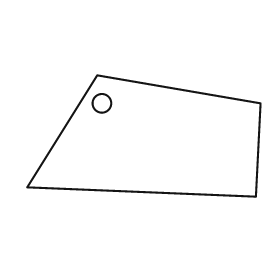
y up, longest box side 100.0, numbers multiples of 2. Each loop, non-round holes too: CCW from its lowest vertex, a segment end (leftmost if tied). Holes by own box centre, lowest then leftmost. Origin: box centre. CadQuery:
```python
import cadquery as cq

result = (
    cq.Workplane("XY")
    .moveTo(48.0, -26.0)
    .lineTo(50.0, 14.0)
    .lineTo(-20.0, 26.0)
    .lineTo(-50.0, -22.0)
    .close()
    .moveTo(-18.0, 14.0)
    .circle(4.0)
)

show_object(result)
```